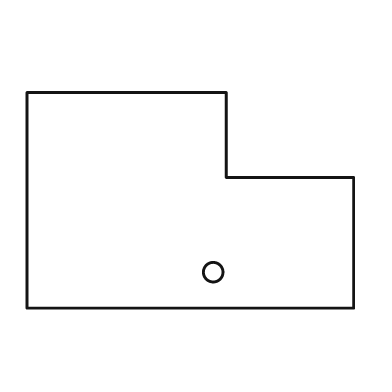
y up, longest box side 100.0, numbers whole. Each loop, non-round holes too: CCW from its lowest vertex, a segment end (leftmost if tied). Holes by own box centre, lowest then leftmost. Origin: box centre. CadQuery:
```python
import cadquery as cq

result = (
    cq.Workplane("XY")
    .moveTo(-50.0, -33.0)
    .lineTo(50.0, -33.0)
    .lineTo(50.0, 7.0)
    .lineTo(11.0, 7.0)
    .lineTo(11.0, 33.0)
    .lineTo(-50.0, 33.0)
    .close()
    .moveTo(7.0, -22.0)
    .circle(3.0)
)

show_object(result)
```